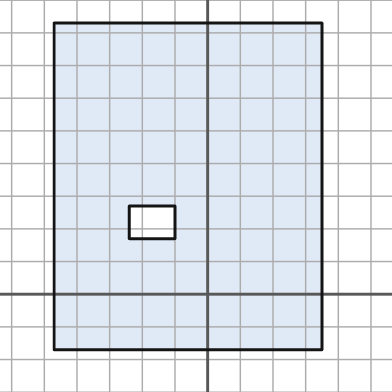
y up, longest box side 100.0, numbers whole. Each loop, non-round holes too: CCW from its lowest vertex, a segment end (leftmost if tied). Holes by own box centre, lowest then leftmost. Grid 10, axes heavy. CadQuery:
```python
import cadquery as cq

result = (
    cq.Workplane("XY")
    .moveTo(-47.0, -17.0)
    .lineTo(35.0, -17.0)
    .lineTo(35.0, 83.0)
    .lineTo(-47.0, 83.0)
    .close()
    .moveTo(-24.0, 17.0)
    .lineTo(-10.0, 17.0)
    .lineTo(-10.0, 27.0)
    .lineTo(-24.0, 27.0)
    .close()
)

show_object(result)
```